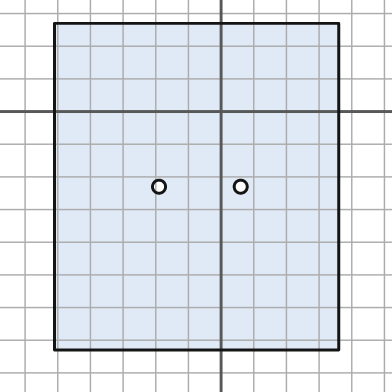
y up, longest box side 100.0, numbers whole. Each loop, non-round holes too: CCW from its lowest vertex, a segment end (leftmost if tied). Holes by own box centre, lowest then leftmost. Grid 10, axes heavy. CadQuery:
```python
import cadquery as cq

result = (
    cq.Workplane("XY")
    .moveTo(-51.0, -73.0)
    .lineTo(36.0, -73.0)
    .lineTo(36.0, 27.0)
    .lineTo(-51.0, 27.0)
    .close()
    .moveTo(-19.0, -23.0)
    .circle(2.0)
    .moveTo(6.0, -23.0)
    .circle(2.0)
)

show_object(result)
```